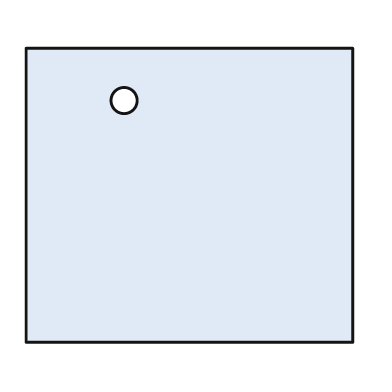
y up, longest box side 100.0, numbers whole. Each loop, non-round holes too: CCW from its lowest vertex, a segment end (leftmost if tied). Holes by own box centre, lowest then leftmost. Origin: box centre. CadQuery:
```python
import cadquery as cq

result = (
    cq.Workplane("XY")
    .moveTo(-50.0, -45.0)
    .lineTo(50.0, -45.0)
    .lineTo(50.0, 45.0)
    .lineTo(-50.0, 45.0)
    .close()
    .moveTo(-20.0, 29.0)
    .circle(4.0)
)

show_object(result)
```